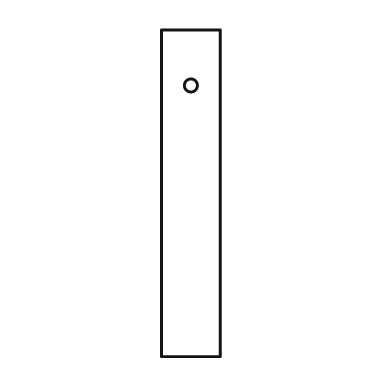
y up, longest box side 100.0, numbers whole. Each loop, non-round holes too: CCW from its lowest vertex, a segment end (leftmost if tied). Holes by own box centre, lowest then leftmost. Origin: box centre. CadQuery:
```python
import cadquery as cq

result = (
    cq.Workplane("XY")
    .moveTo(-9.0, -50.0)
    .lineTo(9.0, -50.0)
    .lineTo(9.0, 50.0)
    .lineTo(-9.0, 50.0)
    .close()
    .moveTo(0.0, 33.0)
    .circle(2.0)
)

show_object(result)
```